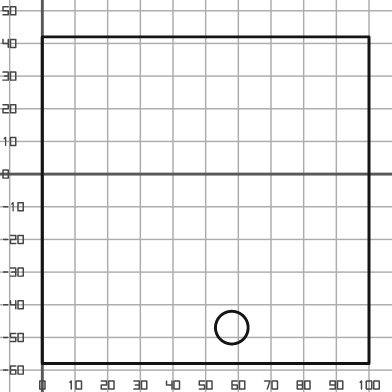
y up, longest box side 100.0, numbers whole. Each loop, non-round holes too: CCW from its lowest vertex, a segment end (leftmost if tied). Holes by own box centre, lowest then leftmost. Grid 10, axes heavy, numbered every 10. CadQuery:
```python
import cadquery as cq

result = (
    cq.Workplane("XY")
    .moveTo(0.0, -58.0)
    .lineTo(100.0, -58.0)
    .lineTo(100.0, 42.0)
    .lineTo(0.0, 42.0)
    .close()
    .moveTo(58.0, -47.0)
    .circle(5.0)
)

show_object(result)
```